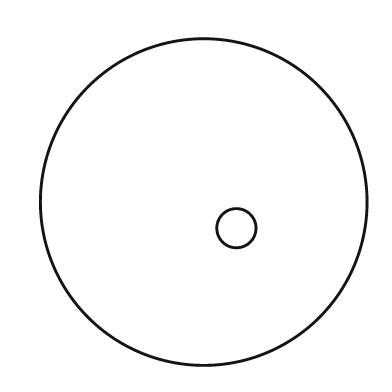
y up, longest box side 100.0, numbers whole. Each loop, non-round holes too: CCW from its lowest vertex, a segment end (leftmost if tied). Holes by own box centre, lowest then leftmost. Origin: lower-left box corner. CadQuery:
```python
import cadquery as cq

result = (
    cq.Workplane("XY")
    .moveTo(50.0, 50.0)
    .circle(50.0)
    .moveTo(60.0, 42.0)
    .circle(6.0)
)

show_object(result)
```